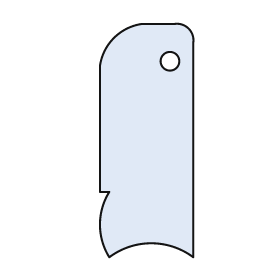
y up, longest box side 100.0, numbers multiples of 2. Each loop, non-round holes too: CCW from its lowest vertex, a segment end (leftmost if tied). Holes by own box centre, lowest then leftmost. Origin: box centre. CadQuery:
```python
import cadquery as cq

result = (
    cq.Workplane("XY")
    .moveTo(-16.0, -50.0)
    .threePointArc((2.0, -44.0), (20.0, -50.0))
    .lineTo(20.0, 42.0)
    .threePointArc((18.0, 48.0), (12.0, 50.0))
    .lineTo(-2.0, 50.0)
    .threePointArc((-14.0, 44.0), (-20.0, 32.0))
    .lineTo(-20.0, -22.0)
    .lineTo(-16.0, -22.0)
    .threePointArc((-20.0, -36.0), (-16.0, -50.0))
    .close()
    .moveTo(10.0, 34.0)
    .circle(4.0)
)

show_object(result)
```